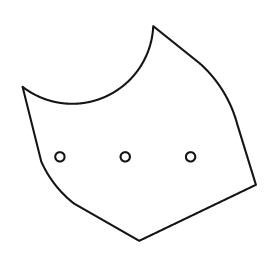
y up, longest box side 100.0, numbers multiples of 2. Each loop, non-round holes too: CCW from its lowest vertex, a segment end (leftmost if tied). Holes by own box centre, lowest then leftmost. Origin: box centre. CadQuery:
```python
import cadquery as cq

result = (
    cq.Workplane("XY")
    .moveTo(0.0, -46.0)
    .lineTo(50.0, -22.0)
    .lineTo(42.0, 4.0)
    .threePointArc((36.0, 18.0), (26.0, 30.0))
    .lineTo(6.0, 46.0)
    .threePointArc((-14.0, 16.0), (-50.0, 20.0))
    .lineTo(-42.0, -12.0)
    .threePointArc((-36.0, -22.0), (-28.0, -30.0))
    .close()
    .moveTo(-34.0, -10.0)
    .circle(2.0)
    .moveTo(-6.0, -10.0)
    .circle(2.0)
    .moveTo(22.0, -10.0)
    .circle(2.0)
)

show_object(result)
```